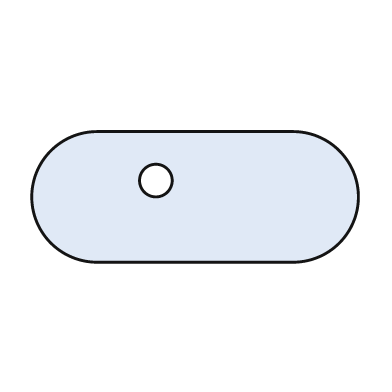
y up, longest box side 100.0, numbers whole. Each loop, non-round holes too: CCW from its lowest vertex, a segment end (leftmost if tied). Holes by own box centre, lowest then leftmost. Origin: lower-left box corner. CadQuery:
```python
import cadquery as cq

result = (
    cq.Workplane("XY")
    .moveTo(20.0, 0.0)
    .lineTo(80.0, 0.0)
    .threePointArc((100.0, 20.0), (80.0, 40.0))
    .lineTo(20.0, 40.0)
    .threePointArc((0.0, 20.0), (20.0, 0.0))
    .close()
    .moveTo(38.0, 25.0)
    .circle(5.0)
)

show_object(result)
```